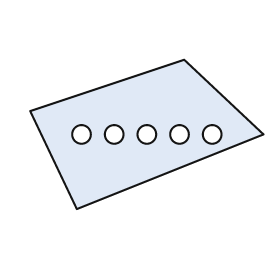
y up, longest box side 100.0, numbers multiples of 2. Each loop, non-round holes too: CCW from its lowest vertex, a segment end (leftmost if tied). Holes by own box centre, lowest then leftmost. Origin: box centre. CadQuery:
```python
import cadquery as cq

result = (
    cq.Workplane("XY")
    .moveTo(-30.0, -32.0)
    .lineTo(50.0, 0.0)
    .lineTo(16.0, 32.0)
    .lineTo(-50.0, 10.0)
    .close()
    .moveTo(-28.0, 0.0)
    .circle(4.0)
    .moveTo(-14.0, 0.0)
    .circle(4.0)
    .moveTo(0.0, 0.0)
    .circle(4.0)
    .moveTo(14.0, 0.0)
    .circle(4.0)
    .moveTo(28.0, 0.0)
    .circle(4.0)
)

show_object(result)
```